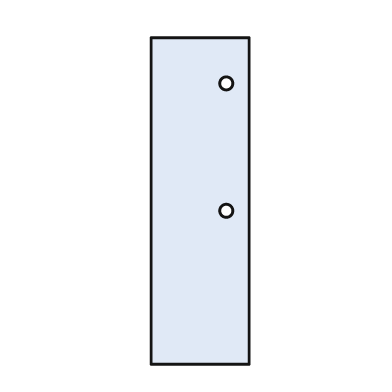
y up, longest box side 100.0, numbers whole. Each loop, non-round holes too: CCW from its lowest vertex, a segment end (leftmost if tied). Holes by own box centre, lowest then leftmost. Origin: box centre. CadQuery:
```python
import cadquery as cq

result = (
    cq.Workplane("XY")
    .moveTo(-15.0, -50.0)
    .lineTo(15.0, -50.0)
    .lineTo(15.0, 50.0)
    .lineTo(-15.0, 50.0)
    .close()
    .moveTo(8.0, -3.0)
    .circle(2.0)
    .moveTo(8.0, 36.0)
    .circle(2.0)
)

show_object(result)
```